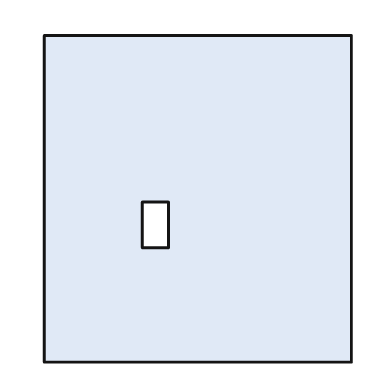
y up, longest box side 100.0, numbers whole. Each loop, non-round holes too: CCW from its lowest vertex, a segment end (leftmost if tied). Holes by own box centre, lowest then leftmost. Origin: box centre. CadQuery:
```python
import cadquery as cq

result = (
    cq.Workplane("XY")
    .moveTo(-47.0, -50.0)
    .lineTo(47.0, -50.0)
    .lineTo(47.0, 50.0)
    .lineTo(-47.0, 50.0)
    .close()
    .moveTo(-17.0, -15.0)
    .lineTo(-9.0, -15.0)
    .lineTo(-9.0, -1.0)
    .lineTo(-17.0, -1.0)
    .close()
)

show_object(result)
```